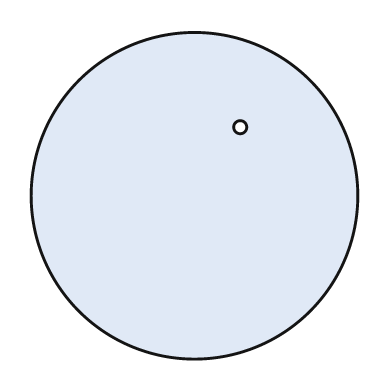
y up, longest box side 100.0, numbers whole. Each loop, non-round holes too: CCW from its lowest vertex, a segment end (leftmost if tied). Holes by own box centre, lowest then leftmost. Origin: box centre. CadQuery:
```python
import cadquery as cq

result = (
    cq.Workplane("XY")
    .moveTo(0.0, 0.0)
    .circle(50.0)
    .moveTo(14.0, 21.0)
    .circle(2.0)
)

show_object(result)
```